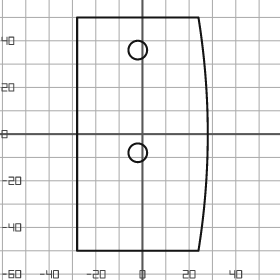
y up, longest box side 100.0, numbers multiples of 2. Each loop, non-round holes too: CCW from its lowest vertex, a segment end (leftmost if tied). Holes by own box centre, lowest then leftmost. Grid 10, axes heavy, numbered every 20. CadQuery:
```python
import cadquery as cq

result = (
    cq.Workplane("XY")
    .moveTo(-28.0, -50.0)
    .lineTo(24.0, -50.0)
    .threePointArc((28.0, 0.0), (24.0, 50.0))
    .lineTo(-28.0, 50.0)
    .close()
    .moveTo(-2.0, -8.0)
    .circle(4.0)
    .moveTo(-2.0, 36.0)
    .circle(4.0)
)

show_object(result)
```